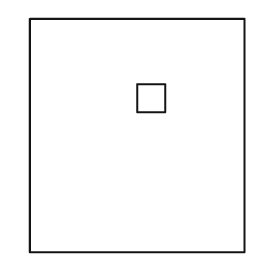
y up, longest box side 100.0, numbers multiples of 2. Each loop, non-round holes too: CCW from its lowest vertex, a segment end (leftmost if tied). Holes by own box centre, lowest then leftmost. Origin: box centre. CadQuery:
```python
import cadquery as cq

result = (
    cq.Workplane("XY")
    .moveTo(-46.0, -50.0)
    .lineTo(46.0, -50.0)
    .lineTo(46.0, 50.0)
    .lineTo(-46.0, 50.0)
    .close()
    .moveTo(0.0, 10.0)
    .lineTo(12.0, 10.0)
    .lineTo(12.0, 22.0)
    .lineTo(0.0, 22.0)
    .close()
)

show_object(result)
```